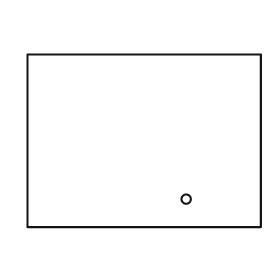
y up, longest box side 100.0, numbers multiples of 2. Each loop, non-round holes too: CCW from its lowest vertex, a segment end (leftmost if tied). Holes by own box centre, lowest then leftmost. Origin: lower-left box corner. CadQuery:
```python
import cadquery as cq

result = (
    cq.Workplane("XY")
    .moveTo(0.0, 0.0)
    .lineTo(100.0, 0.0)
    .lineTo(100.0, 74.0)
    .lineTo(0.0, 74.0)
    .close()
    .moveTo(68.0, 12.0)
    .circle(2.0)
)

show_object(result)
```